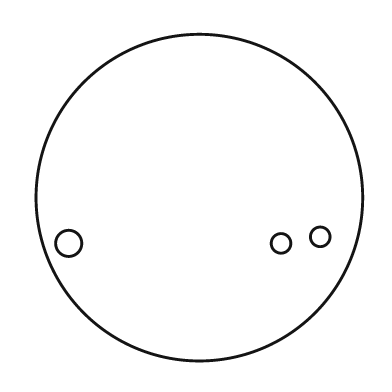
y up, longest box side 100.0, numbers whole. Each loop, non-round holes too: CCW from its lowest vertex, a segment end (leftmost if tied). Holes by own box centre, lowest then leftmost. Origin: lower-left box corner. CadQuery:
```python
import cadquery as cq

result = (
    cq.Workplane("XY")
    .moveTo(50.0, 50.0)
    .circle(50.0)
    .moveTo(10.0, 36.0)
    .circle(4.0)
    .moveTo(75.0, 36.0)
    .circle(3.0)
    .moveTo(87.0, 38.0)
    .circle(3.0)
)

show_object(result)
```